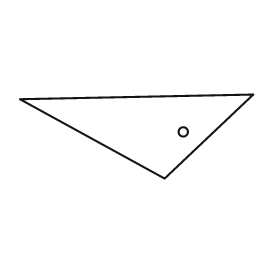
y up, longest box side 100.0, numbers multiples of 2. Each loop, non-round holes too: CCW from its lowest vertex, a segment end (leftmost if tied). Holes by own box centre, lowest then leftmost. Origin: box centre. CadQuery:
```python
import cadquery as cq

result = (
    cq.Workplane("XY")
    .moveTo(12.0, -18.0)
    .lineTo(50.0, 18.0)
    .lineTo(-50.0, 16.0)
    .close()
    .moveTo(20.0, 2.0)
    .circle(2.0)
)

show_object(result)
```